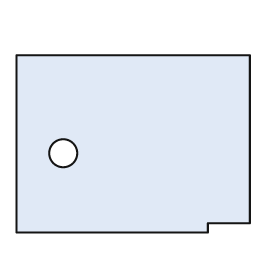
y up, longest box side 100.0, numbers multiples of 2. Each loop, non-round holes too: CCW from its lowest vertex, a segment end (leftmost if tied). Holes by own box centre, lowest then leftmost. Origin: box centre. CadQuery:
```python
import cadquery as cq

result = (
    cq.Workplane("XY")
    .moveTo(-50.0, -38.0)
    .lineTo(32.0, -38.0)
    .lineTo(32.0, -34.0)
    .lineTo(50.0, -34.0)
    .lineTo(50.0, 38.0)
    .lineTo(-50.0, 38.0)
    .close()
    .moveTo(-30.0, -4.0)
    .circle(6.0)
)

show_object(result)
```